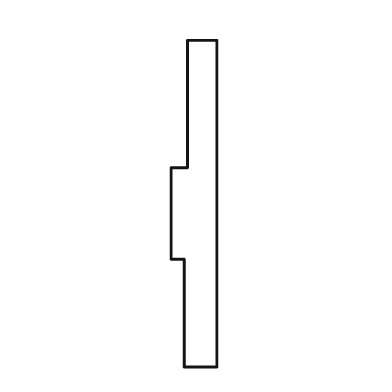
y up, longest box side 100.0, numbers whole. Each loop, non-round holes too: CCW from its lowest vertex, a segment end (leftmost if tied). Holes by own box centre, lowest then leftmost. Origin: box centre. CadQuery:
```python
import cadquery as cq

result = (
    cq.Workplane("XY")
    .moveTo(-3.0, -50.0)
    .lineTo(7.0, -50.0)
    .lineTo(7.0, 50.0)
    .lineTo(-2.0, 50.0)
    .lineTo(-2.0, 11.0)
    .lineTo(-7.0, 11.0)
    .lineTo(-7.0, -17.0)
    .lineTo(-3.0, -17.0)
    .close()
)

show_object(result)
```